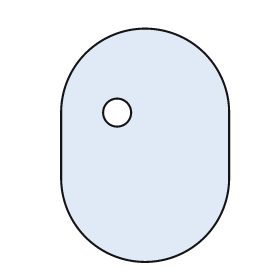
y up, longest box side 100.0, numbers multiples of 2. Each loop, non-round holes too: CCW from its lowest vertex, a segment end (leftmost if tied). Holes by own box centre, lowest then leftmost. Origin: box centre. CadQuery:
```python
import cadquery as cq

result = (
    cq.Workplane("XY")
    .moveTo(-36.0, -14.0)
    .threePointArc((0.0, -50.0), (36.0, -14.0))
    .lineTo(36.0, 14.0)
    .threePointArc((0.0, 50.0), (-36.0, 14.0))
    .close()
    .moveTo(-12.0, 14.0)
    .circle(6.0)
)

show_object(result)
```